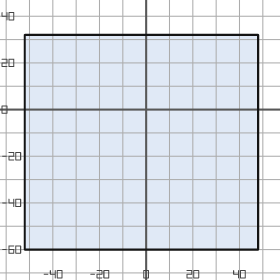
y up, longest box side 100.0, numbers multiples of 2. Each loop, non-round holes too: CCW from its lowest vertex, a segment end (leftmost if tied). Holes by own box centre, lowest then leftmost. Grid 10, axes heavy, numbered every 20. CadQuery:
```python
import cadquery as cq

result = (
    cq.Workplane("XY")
    .moveTo(-52.0, -60.0)
    .lineTo(48.0, -60.0)
    .lineTo(48.0, 32.0)
    .lineTo(-52.0, 32.0)
    .close()
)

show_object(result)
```